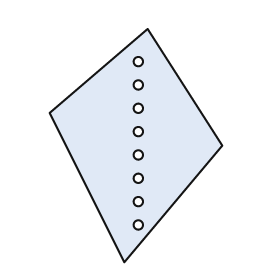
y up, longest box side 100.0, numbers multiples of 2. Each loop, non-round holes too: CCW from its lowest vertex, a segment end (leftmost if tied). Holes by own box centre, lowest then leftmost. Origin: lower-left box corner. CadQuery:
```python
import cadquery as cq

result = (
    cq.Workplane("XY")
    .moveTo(32.0, 0.0)
    .lineTo(74.0, 50.0)
    .lineTo(42.0, 100.0)
    .lineTo(0.0, 64.0)
    .close()
    .moveTo(38.0, 16.0)
    .circle(2.0)
    .moveTo(38.0, 26.0)
    .circle(2.0)
    .moveTo(38.0, 36.0)
    .circle(2.0)
    .moveTo(38.0, 46.0)
    .circle(2.0)
    .moveTo(38.0, 56.0)
    .circle(2.0)
    .moveTo(38.0, 66.0)
    .circle(2.0)
    .moveTo(38.0, 76.0)
    .circle(2.0)
    .moveTo(38.0, 86.0)
    .circle(2.0)
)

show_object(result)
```